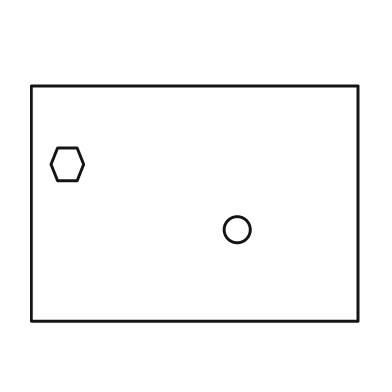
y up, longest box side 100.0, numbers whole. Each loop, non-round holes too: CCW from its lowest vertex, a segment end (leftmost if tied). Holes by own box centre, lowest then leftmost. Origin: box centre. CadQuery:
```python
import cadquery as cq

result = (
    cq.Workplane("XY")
    .moveTo(-50.0, -36.0)
    .lineTo(50.0, -36.0)
    .lineTo(50.0, 36.0)
    .lineTo(-50.0, 36.0)
    .close()
    .moveTo(13.0, -8.0)
    .circle(4.0)
    .moveTo(-42.0, 7.0)
    .lineTo(-36.0, 7.0)
    .lineTo(-34.0, 12.0)
    .lineTo(-36.0, 17.0)
    .lineTo(-42.0, 17.0)
    .lineTo(-44.0, 12.0)
    .close()
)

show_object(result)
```